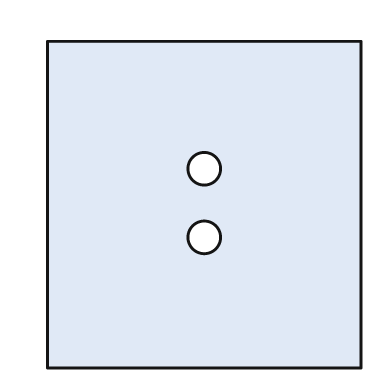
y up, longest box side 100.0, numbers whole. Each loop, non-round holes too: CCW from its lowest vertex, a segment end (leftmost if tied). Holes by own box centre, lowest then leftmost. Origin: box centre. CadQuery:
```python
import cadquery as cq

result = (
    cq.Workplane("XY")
    .moveTo(-48.0, -50.0)
    .lineTo(48.0, -50.0)
    .lineTo(48.0, 50.0)
    .lineTo(-48.0, 50.0)
    .close()
    .moveTo(0.0, -10.0)
    .circle(5.0)
    .moveTo(0.0, 11.0)
    .circle(5.0)
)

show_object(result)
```